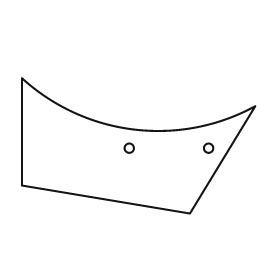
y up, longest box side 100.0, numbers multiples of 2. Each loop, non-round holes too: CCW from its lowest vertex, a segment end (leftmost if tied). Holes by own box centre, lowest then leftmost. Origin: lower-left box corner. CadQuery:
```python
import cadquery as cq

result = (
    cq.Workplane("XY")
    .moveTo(72.0, 0.0)
    .lineTo(100.0, 46.0)
    .threePointArc((48.0, 36.0), (0.0, 58.0))
    .lineTo(0.0, 12.0)
    .close()
    .moveTo(46.0, 28.0)
    .circle(2.0)
    .moveTo(80.0, 28.0)
    .circle(2.0)
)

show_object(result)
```